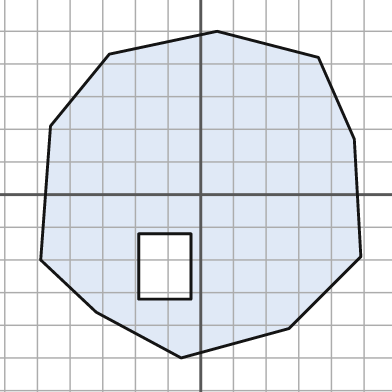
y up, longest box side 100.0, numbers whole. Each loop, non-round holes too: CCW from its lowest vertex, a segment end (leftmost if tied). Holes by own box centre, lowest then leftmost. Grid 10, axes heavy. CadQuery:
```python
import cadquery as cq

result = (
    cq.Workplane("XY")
    .moveTo(-6.0, -50.0)
    .lineTo(27.0, -41.0)
    .lineTo(49.0, -19.0)
    .lineTo(47.0, 17.0)
    .lineTo(36.0, 42.0)
    .lineTo(5.0, 50.0)
    .lineTo(-28.0, 43.0)
    .lineTo(-46.0, 21.0)
    .lineTo(-49.0, -20.0)
    .lineTo(-32.0, -36.0)
    .close()
    .moveTo(-19.0, -32.0)
    .lineTo(-3.0, -32.0)
    .lineTo(-3.0, -12.0)
    .lineTo(-19.0, -12.0)
    .close()
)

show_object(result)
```